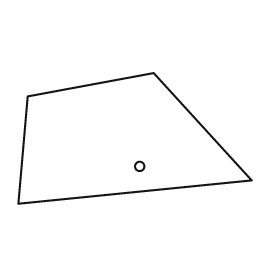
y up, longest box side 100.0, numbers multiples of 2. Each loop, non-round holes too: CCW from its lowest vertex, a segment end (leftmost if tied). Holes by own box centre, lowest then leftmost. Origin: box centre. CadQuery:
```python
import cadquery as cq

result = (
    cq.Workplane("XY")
    .moveTo(-50.0, -28.0)
    .lineTo(50.0, -18.0)
    .lineTo(8.0, 28.0)
    .lineTo(-46.0, 18.0)
    .close()
    .moveTo(2.0, -12.0)
    .circle(2.0)
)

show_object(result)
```